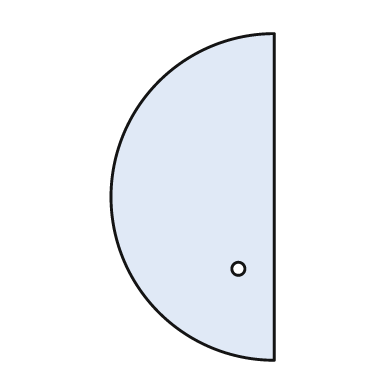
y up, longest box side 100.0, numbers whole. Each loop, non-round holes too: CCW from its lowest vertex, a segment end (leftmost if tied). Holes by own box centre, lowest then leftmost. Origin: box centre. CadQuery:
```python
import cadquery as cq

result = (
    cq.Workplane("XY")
    .moveTo(25.0, -50.0)
    .lineTo(25.0, 50.0)
    .threePointArc((-25.0, 0.0), (25.0, -50.0))
    .close()
    .moveTo(14.0, -22.0)
    .circle(2.0)
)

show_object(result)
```